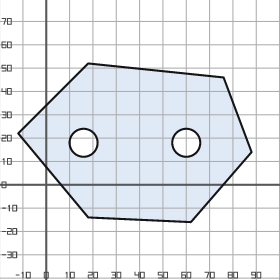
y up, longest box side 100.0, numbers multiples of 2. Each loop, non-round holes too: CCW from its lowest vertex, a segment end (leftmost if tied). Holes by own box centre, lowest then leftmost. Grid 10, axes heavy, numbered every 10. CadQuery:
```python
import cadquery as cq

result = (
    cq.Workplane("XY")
    .moveTo(62.0, -16.0)
    .lineTo(88.0, 14.0)
    .lineTo(76.0, 46.0)
    .lineTo(18.0, 52.0)
    .lineTo(-12.0, 22.0)
    .lineTo(18.0, -14.0)
    .close()
    .moveTo(16.0, 18.0)
    .circle(6.0)
    .moveTo(60.0, 18.0)
    .circle(6.0)
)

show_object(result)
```